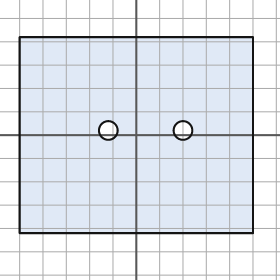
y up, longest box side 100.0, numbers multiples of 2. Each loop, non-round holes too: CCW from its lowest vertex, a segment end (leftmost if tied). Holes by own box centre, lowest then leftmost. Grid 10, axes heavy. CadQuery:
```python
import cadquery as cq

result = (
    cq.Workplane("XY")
    .moveTo(-50.0, -42.0)
    .lineTo(50.0, -42.0)
    .lineTo(50.0, 42.0)
    .lineTo(-50.0, 42.0)
    .close()
    .moveTo(-12.0, 2.0)
    .circle(4.0)
    .moveTo(20.0, 2.0)
    .circle(4.0)
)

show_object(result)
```